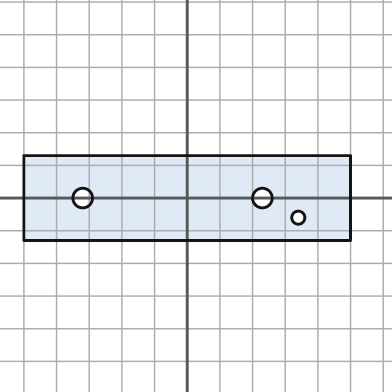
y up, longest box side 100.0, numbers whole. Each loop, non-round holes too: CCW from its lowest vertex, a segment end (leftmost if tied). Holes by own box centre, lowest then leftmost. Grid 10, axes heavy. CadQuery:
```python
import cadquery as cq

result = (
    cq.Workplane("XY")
    .moveTo(-50.0, -13.0)
    .lineTo(50.0, -13.0)
    .lineTo(50.0, 13.0)
    .lineTo(-50.0, 13.0)
    .close()
    .moveTo(34.0, -6.0)
    .circle(2.0)
    .moveTo(-32.0, 0.0)
    .circle(3.0)
    .moveTo(23.0, 0.0)
    .circle(3.0)
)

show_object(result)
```